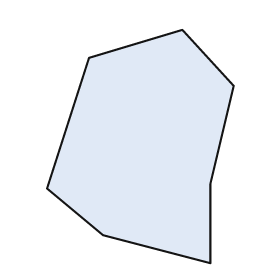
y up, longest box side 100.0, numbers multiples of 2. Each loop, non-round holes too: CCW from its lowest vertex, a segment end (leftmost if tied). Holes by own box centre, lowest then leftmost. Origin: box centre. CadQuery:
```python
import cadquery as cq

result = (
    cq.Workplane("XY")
    .moveTo(30.0, -50.0)
    .lineTo(30.0, -16.0)
    .lineTo(40.0, 26.0)
    .lineTo(18.0, 50.0)
    .lineTo(-22.0, 38.0)
    .lineTo(-40.0, -18.0)
    .lineTo(-16.0, -38.0)
    .close()
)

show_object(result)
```